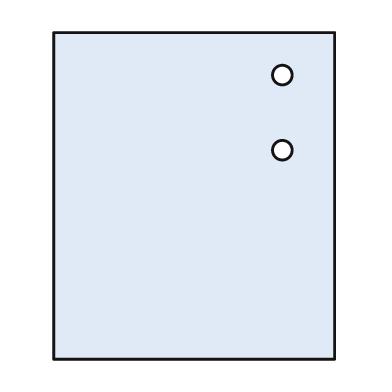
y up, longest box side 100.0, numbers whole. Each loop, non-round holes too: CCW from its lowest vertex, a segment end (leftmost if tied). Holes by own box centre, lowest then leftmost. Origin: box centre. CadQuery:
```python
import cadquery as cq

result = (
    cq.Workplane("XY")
    .moveTo(-43.0, -50.0)
    .lineTo(43.0, -50.0)
    .lineTo(43.0, 50.0)
    .lineTo(-43.0, 50.0)
    .close()
    .moveTo(27.0, 14.0)
    .circle(3.0)
    .moveTo(27.0, 37.0)
    .circle(3.0)
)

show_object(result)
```